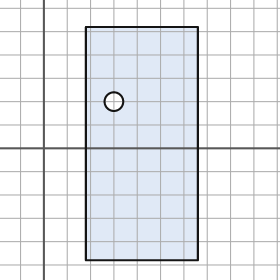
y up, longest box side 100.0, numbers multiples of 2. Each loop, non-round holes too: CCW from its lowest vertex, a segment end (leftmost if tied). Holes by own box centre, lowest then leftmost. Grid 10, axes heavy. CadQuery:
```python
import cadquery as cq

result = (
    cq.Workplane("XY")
    .moveTo(18.0, -48.0)
    .lineTo(66.0, -48.0)
    .lineTo(66.0, 52.0)
    .lineTo(18.0, 52.0)
    .close()
    .moveTo(30.0, 20.0)
    .circle(4.0)
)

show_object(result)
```